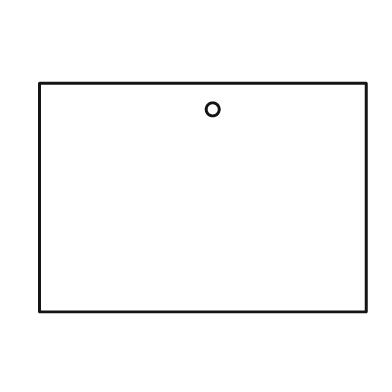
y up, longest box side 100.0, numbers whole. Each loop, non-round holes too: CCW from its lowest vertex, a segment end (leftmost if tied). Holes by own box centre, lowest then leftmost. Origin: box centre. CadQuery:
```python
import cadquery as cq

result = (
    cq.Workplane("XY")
    .moveTo(-50.0, -35.0)
    .lineTo(50.0, -35.0)
    .lineTo(50.0, 35.0)
    .lineTo(-50.0, 35.0)
    .close()
    .moveTo(3.0, 27.0)
    .circle(2.0)
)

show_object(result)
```